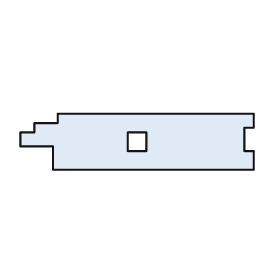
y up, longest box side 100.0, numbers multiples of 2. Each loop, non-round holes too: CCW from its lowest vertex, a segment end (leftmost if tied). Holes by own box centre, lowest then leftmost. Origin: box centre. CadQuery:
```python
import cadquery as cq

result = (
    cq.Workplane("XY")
    .moveTo(-36.0, -12.0)
    .lineTo(50.0, -12.0)
    .lineTo(50.0, -4.0)
    .lineTo(46.0, -4.0)
    .lineTo(46.0, 6.0)
    .lineTo(50.0, 6.0)
    .lineTo(50.0, 12.0)
    .lineTo(-34.0, 12.0)
    .lineTo(-34.0, 8.0)
    .lineTo(-44.0, 8.0)
    .lineTo(-44.0, 4.0)
    .lineTo(-50.0, 4.0)
    .lineTo(-50.0, -2.0)
    .lineTo(-36.0, -2.0)
    .close()
    .moveTo(-4.0, -4.0)
    .lineTo(4.0, -4.0)
    .lineTo(4.0, 4.0)
    .lineTo(-4.0, 4.0)
    .close()
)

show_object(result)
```